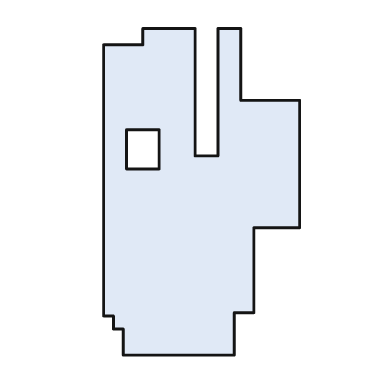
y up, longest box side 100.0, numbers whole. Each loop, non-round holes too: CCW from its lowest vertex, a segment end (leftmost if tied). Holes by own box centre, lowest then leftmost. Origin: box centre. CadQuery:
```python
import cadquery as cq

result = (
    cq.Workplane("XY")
    .moveTo(-24.0, -50.0)
    .lineTo(10.0, -50.0)
    .lineTo(10.0, -37.0)
    .lineTo(16.0, -37.0)
    .lineTo(16.0, -11.0)
    .lineTo(30.0, -11.0)
    .lineTo(30.0, 28.0)
    .lineTo(12.0, 28.0)
    .lineTo(12.0, 50.0)
    .lineTo(5.0, 50.0)
    .lineTo(5.0, 11.0)
    .lineTo(-2.0, 11.0)
    .lineTo(-2.0, 50.0)
    .lineTo(-18.0, 50.0)
    .lineTo(-18.0, 45.0)
    .lineTo(-30.0, 45.0)
    .lineTo(-30.0, -38.0)
    .lineTo(-27.0, -38.0)
    .lineTo(-27.0, -42.0)
    .lineTo(-24.0, -42.0)
    .close()
    .moveTo(-23.0, 7.0)
    .lineTo(-13.0, 7.0)
    .lineTo(-13.0, 19.0)
    .lineTo(-23.0, 19.0)
    .close()
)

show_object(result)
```